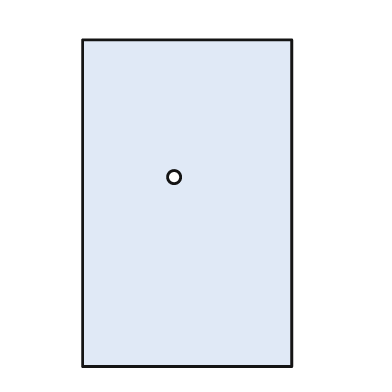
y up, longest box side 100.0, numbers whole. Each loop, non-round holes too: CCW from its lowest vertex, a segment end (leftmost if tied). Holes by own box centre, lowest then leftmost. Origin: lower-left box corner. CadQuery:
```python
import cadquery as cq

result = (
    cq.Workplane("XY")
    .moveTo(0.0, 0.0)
    .lineTo(64.0, 0.0)
    .lineTo(64.0, 100.0)
    .lineTo(0.0, 100.0)
    .close()
    .moveTo(28.0, 58.0)
    .circle(2.0)
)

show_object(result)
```